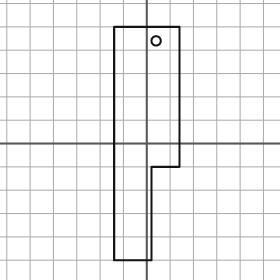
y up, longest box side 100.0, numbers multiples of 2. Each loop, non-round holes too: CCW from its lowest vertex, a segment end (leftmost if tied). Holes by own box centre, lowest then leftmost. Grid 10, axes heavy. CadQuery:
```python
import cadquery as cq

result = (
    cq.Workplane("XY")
    .moveTo(-14.0, -50.0)
    .lineTo(2.0, -50.0)
    .lineTo(2.0, -10.0)
    .lineTo(14.0, -10.0)
    .lineTo(14.0, 50.0)
    .lineTo(-14.0, 50.0)
    .close()
    .moveTo(4.0, 44.0)
    .circle(2.0)
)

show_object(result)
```